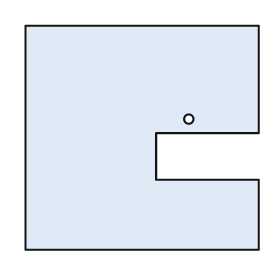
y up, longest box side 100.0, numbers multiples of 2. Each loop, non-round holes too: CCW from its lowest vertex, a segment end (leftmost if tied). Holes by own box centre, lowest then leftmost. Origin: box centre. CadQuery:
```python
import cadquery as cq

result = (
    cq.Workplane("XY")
    .moveTo(-50.0, -48.0)
    .lineTo(50.0, -48.0)
    .lineTo(50.0, -18.0)
    .lineTo(6.0, -18.0)
    .lineTo(6.0, 2.0)
    .lineTo(50.0, 2.0)
    .lineTo(50.0, 48.0)
    .lineTo(-50.0, 48.0)
    .close()
    .moveTo(20.0, 8.0)
    .circle(2.0)
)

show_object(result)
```